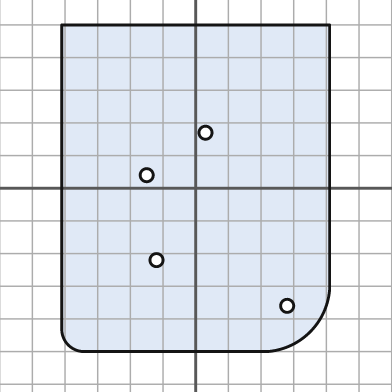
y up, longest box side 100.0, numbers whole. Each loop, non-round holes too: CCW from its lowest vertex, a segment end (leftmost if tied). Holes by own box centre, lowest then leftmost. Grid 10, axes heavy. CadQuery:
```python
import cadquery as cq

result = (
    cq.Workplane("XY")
    .moveTo(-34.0, -50.0)
    .lineTo(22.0, -50.0)
    .threePointArc((35.0, -44.0), (41.0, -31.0))
    .lineTo(41.0, 50.0)
    .lineTo(-41.0, 50.0)
    .lineTo(-41.0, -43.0)
    .threePointArc((-39.0, -48.0), (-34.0, -50.0))
    .close()
    .moveTo(28.0, -36.0)
    .circle(2.0)
    .moveTo(-12.0, -22.0)
    .circle(2.0)
    .moveTo(-15.0, 4.0)
    .circle(2.0)
    .moveTo(3.0, 17.0)
    .circle(2.0)
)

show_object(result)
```